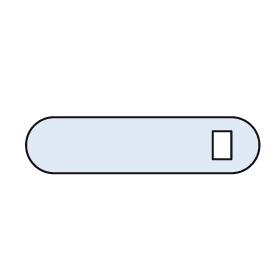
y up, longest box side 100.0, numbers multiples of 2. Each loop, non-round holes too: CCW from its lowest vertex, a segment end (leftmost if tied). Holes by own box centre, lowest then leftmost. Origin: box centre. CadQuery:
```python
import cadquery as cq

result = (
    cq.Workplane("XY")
    .moveTo(-38.0, -12.0)
    .lineTo(38.0, -12.0)
    .threePointArc((50.0, 0.0), (38.0, 12.0))
    .lineTo(-38.0, 12.0)
    .threePointArc((-50.0, 0.0), (-38.0, -12.0))
    .close()
    .moveTo(30.0, -6.0)
    .lineTo(38.0, -6.0)
    .lineTo(38.0, 6.0)
    .lineTo(30.0, 6.0)
    .close()
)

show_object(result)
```